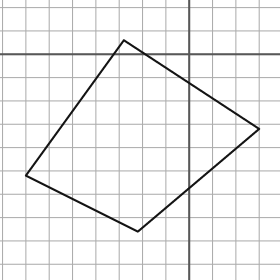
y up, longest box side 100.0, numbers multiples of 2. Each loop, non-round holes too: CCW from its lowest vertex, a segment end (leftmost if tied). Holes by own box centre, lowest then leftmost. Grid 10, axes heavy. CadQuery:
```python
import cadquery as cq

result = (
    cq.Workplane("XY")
    .moveTo(-22.0, -76.0)
    .lineTo(30.0, -32.0)
    .lineTo(-28.0, 6.0)
    .lineTo(-70.0, -52.0)
    .close()
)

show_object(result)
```